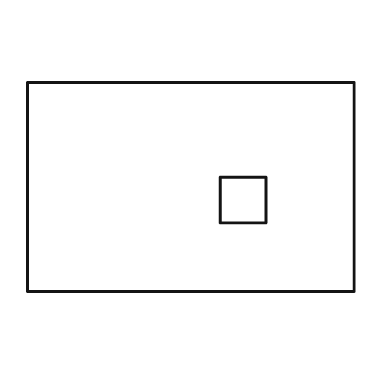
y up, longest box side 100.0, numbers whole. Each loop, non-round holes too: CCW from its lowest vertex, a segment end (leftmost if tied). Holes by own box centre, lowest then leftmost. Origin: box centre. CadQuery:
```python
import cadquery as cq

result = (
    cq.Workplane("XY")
    .moveTo(-50.0, -32.0)
    .lineTo(50.0, -32.0)
    .lineTo(50.0, 32.0)
    .lineTo(-50.0, 32.0)
    .close()
    .moveTo(9.0, -11.0)
    .lineTo(23.0, -11.0)
    .lineTo(23.0, 3.0)
    .lineTo(9.0, 3.0)
    .close()
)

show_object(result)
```